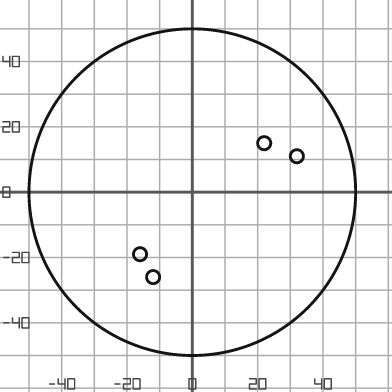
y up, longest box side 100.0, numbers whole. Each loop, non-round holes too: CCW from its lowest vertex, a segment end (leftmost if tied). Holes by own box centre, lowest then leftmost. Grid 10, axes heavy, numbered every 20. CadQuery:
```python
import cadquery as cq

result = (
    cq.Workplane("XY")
    .moveTo(0.0, 0.0)
    .circle(50.0)
    .moveTo(-12.0, -26.0)
    .circle(2.0)
    .moveTo(-16.0, -19.0)
    .circle(2.0)
    .moveTo(32.0, 11.0)
    .circle(2.0)
    .moveTo(22.0, 15.0)
    .circle(2.0)
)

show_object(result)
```